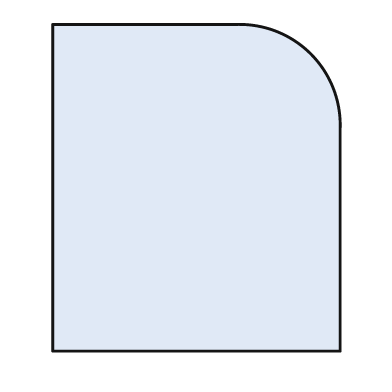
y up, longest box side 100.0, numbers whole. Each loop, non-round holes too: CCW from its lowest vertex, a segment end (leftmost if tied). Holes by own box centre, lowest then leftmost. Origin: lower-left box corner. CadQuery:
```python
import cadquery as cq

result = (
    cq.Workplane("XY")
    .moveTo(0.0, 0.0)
    .lineTo(88.0, 0.0)
    .lineTo(88.0, 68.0)
    .threePointArc((79.0, 91.0), (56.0, 100.0))
    .lineTo(0.0, 100.0)
    .close()
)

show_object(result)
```